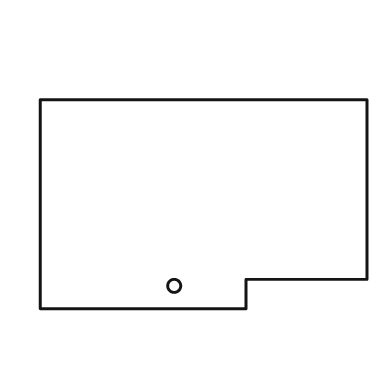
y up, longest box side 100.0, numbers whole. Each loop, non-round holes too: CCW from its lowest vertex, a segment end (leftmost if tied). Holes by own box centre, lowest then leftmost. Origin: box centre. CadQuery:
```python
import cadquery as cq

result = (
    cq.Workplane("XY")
    .moveTo(-50.0, -32.0)
    .lineTo(13.0, -32.0)
    .lineTo(13.0, -23.0)
    .lineTo(50.0, -23.0)
    .lineTo(50.0, 32.0)
    .lineTo(-50.0, 32.0)
    .close()
    .moveTo(-9.0, -25.0)
    .circle(2.0)
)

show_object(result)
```